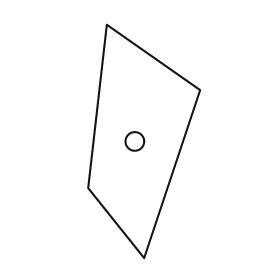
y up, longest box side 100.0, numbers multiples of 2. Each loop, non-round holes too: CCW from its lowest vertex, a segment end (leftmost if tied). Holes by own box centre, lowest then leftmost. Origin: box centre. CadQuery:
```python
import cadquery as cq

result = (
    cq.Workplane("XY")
    .moveTo(0.0, -50.0)
    .lineTo(24.0, 22.0)
    .lineTo(-16.0, 50.0)
    .lineTo(-24.0, -20.0)
    .close()
    .moveTo(-4.0, 0.0)
    .circle(4.0)
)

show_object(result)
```